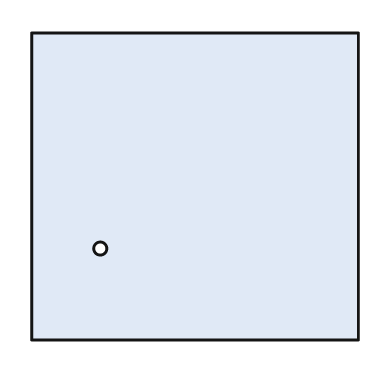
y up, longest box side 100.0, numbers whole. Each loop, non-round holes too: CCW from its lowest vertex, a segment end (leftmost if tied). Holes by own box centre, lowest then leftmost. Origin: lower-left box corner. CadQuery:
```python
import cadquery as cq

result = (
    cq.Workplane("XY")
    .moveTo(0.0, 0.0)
    .lineTo(100.0, 0.0)
    .lineTo(100.0, 94.0)
    .lineTo(0.0, 94.0)
    .close()
    .moveTo(21.0, 28.0)
    .circle(2.0)
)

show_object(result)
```